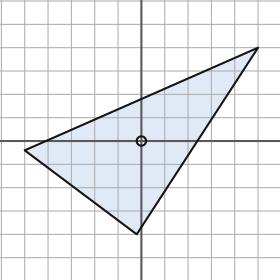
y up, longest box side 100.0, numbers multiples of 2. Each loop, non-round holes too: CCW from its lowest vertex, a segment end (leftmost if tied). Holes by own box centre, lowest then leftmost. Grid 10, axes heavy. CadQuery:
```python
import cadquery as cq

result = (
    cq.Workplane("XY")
    .moveTo(-2.0, -40.0)
    .lineTo(50.0, 40.0)
    .lineTo(-50.0, -4.0)
    .close()
    .moveTo(0.0, 0.0)
    .circle(2.0)
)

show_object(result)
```